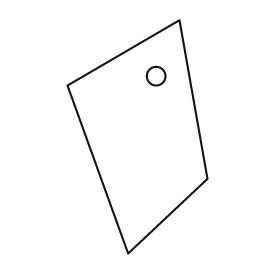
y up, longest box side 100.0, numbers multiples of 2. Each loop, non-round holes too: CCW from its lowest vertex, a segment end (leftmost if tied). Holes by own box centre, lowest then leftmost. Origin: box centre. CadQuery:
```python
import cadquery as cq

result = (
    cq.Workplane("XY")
    .moveTo(-4.0, -50.0)
    .lineTo(30.0, -18.0)
    .lineTo(18.0, 50.0)
    .lineTo(-30.0, 22.0)
    .close()
    .moveTo(8.0, 26.0)
    .circle(4.0)
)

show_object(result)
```